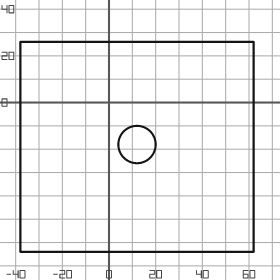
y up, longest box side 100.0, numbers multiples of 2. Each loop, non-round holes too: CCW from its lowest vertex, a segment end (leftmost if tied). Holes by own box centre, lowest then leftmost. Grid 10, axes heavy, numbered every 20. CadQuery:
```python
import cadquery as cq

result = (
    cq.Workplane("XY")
    .moveTo(-38.0, -64.0)
    .lineTo(62.0, -64.0)
    .lineTo(62.0, 26.0)
    .lineTo(-38.0, 26.0)
    .close()
    .moveTo(12.0, -18.0)
    .circle(8.0)
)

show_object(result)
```